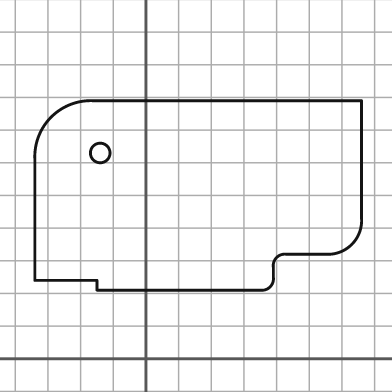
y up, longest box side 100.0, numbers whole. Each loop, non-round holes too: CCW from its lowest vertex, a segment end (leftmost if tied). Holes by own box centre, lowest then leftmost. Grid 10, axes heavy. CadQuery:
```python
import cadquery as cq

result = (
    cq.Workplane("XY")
    .moveTo(-15.0, 21.0)
    .lineTo(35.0, 21.0)
    .threePointArc((38.0, 22.0), (39.0, 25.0))
    .lineTo(39.0, 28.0)
    .threePointArc((40.0, 31.0), (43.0, 32.0))
    .lineTo(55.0, 32.0)
    .threePointArc((63.0, 35.0), (66.0, 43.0))
    .lineTo(66.0, 79.0)
    .lineTo(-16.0, 79.0)
    .threePointArc((-29.0, 74.0), (-34.0, 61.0))
    .lineTo(-34.0, 24.0)
    .lineTo(-15.0, 24.0)
    .close()
    .moveTo(-14.0, 63.0)
    .circle(3.0)
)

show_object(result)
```